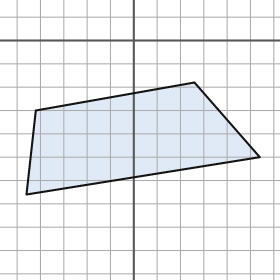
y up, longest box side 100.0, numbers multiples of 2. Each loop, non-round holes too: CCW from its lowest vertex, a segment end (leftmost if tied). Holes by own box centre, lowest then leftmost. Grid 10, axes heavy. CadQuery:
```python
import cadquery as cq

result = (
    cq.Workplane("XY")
    .moveTo(-46.0, -66.0)
    .lineTo(54.0, -50.0)
    .lineTo(26.0, -18.0)
    .lineTo(-42.0, -30.0)
    .close()
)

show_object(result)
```